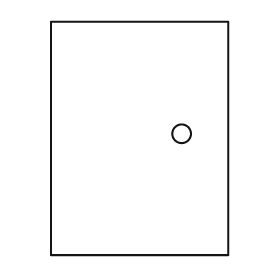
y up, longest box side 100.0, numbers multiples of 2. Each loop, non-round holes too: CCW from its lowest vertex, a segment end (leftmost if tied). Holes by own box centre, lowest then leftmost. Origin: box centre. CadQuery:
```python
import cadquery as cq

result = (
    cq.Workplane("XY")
    .moveTo(-38.0, -50.0)
    .lineTo(38.0, -50.0)
    .lineTo(38.0, 50.0)
    .lineTo(-38.0, 50.0)
    .close()
    .moveTo(18.0, 2.0)
    .circle(4.0)
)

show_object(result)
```